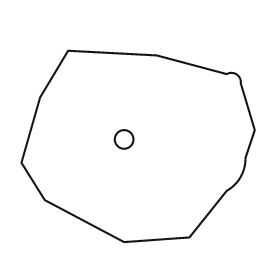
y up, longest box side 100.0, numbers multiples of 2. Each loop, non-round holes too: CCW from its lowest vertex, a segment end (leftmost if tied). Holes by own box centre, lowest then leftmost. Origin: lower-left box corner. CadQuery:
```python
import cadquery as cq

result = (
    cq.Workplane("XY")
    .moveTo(44.0, 0.0)
    .lineTo(72.0, 2.0)
    .lineTo(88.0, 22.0)
    .threePointArc((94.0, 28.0), (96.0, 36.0))
    .lineTo(100.0, 48.0)
    .lineTo(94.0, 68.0)
    .threePointArc((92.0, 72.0), (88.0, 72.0))
    .lineTo(58.0, 80.0)
    .lineTo(20.0, 82.0)
    .lineTo(8.0, 62.0)
    .lineTo(0.0, 34.0)
    .lineTo(10.0, 18.0)
    .close()
    .moveTo(44.0, 44.0)
    .circle(4.0)
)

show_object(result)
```